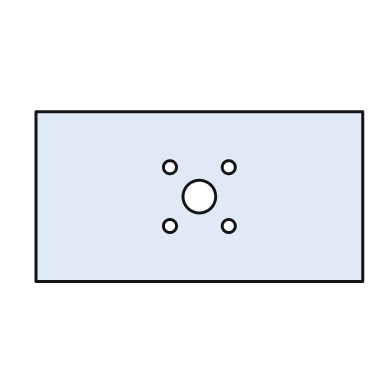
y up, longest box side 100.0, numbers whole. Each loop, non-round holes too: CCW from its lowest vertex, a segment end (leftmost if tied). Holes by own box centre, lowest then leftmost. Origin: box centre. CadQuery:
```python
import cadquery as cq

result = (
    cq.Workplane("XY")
    .moveTo(-50.0, -26.0)
    .lineTo(50.0, -26.0)
    .lineTo(50.0, 26.0)
    .lineTo(-50.0, 26.0)
    .close()
    .moveTo(-9.0, -9.0)
    .circle(2.0)
    .moveTo(9.0, -9.0)
    .circle(2.0)
    .moveTo(0.0, 0.0)
    .circle(5.0)
    .moveTo(-9.0, 9.0)
    .circle(2.0)
    .moveTo(9.0, 9.0)
    .circle(2.0)
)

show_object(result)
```